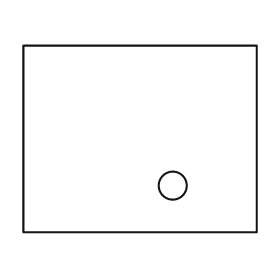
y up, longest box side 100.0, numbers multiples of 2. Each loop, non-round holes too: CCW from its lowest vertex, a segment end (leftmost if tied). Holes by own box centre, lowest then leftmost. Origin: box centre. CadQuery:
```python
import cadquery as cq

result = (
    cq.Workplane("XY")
    .moveTo(-50.0, -40.0)
    .lineTo(50.0, -40.0)
    .lineTo(50.0, 40.0)
    .lineTo(-50.0, 40.0)
    .close()
    .moveTo(14.0, -20.0)
    .circle(6.0)
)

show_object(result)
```